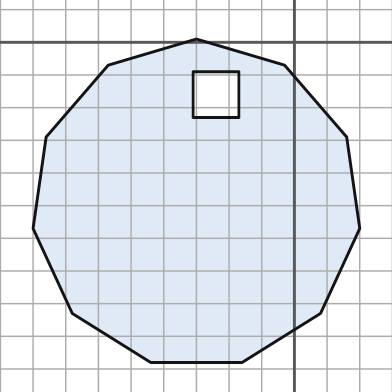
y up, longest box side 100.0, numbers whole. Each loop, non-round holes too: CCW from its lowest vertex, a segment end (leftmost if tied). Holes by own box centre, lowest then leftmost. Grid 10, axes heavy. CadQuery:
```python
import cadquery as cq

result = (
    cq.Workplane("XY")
    .moveTo(-44.0, -98.0)
    .lineTo(-16.0, -98.0)
    .lineTo(8.0, -83.0)
    .lineTo(20.0, -57.0)
    .lineTo(16.0, -29.0)
    .lineTo(-3.0, -7.0)
    .lineTo(-30.0, 1.0)
    .lineTo(-57.0, -7.0)
    .lineTo(-76.0, -29.0)
    .lineTo(-80.0, -57.0)
    .lineTo(-68.0, -83.0)
    .close()
    .moveTo(-31.0, -23.0)
    .lineTo(-17.0, -23.0)
    .lineTo(-17.0, -9.0)
    .lineTo(-31.0, -9.0)
    .close()
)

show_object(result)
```